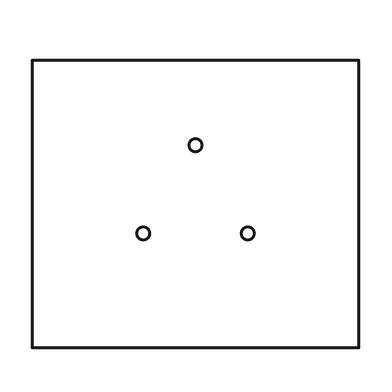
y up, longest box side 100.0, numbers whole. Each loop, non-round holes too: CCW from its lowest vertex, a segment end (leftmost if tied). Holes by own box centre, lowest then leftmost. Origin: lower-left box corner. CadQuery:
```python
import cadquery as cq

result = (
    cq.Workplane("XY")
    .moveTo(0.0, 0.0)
    .lineTo(100.0, 0.0)
    .lineTo(100.0, 88.0)
    .lineTo(0.0, 88.0)
    .close()
    .moveTo(34.0, 35.0)
    .circle(2.0)
    .moveTo(66.0, 35.0)
    .circle(2.0)
    .moveTo(50.0, 62.0)
    .circle(2.0)
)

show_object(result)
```